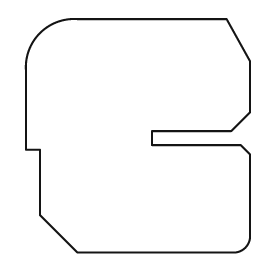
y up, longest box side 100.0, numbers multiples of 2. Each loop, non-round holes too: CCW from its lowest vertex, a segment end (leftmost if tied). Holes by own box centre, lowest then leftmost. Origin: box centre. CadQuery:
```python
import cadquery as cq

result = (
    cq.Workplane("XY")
    .moveTo(-26.0, -50.0)
    .lineTo(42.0, -50.0)
    .threePointArc((46.0, -48.0), (48.0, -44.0))
    .lineTo(48.0, -8.0)
    .lineTo(44.0, -4.0)
    .lineTo(6.0, -4.0)
    .lineTo(6.0, 2.0)
    .lineTo(40.0, 2.0)
    .lineTo(48.0, 10.0)
    .lineTo(48.0, 32.0)
    .lineTo(38.0, 50.0)
    .lineTo(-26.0, 50.0)
    .threePointArc((-42.0, 44.0), (-48.0, 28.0))
    .lineTo(-48.0, -6.0)
    .lineTo(-42.0, -6.0)
    .lineTo(-42.0, -34.0)
    .close()
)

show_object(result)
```